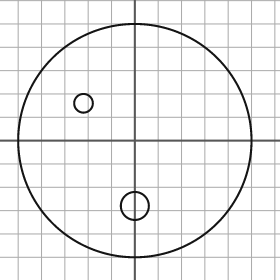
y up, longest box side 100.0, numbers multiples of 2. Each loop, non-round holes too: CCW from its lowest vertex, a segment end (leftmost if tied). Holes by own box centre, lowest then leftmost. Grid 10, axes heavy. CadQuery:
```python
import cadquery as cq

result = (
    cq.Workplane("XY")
    .moveTo(0.0, 0.0)
    .circle(50.0)
    .moveTo(0.0, -28.0)
    .circle(6.0)
    .moveTo(-22.0, 16.0)
    .circle(4.0)
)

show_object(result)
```